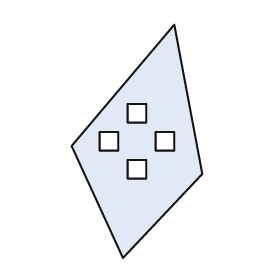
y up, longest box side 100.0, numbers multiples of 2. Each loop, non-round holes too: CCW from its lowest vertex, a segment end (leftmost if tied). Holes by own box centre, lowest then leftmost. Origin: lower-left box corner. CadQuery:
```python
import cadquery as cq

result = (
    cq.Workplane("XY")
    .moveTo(22.0, 0.0)
    .lineTo(56.0, 36.0)
    .lineTo(44.0, 100.0)
    .lineTo(0.0, 48.0)
    .close()
    .moveTo(24.0, 34.0)
    .lineTo(32.0, 34.0)
    .lineTo(32.0, 42.0)
    .lineTo(24.0, 42.0)
    .close()
    .moveTo(12.0, 46.0)
    .lineTo(20.0, 46.0)
    .lineTo(20.0, 54.0)
    .lineTo(12.0, 54.0)
    .close()
    .moveTo(36.0, 46.0)
    .lineTo(44.0, 46.0)
    .lineTo(44.0, 54.0)
    .lineTo(36.0, 54.0)
    .close()
    .moveTo(24.0, 58.0)
    .lineTo(32.0, 58.0)
    .lineTo(32.0, 66.0)
    .lineTo(24.0, 66.0)
    .close()
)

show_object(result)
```